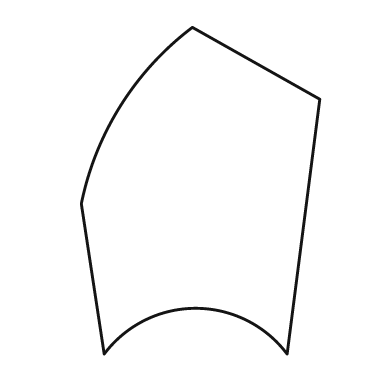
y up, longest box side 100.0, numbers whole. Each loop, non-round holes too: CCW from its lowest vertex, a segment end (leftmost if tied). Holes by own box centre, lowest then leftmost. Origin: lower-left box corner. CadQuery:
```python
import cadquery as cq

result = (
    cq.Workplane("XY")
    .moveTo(7.0, 0.0)
    .threePointArc((35.0, 14.0), (63.0, 0.0))
    .lineTo(73.0, 78.0)
    .lineTo(34.0, 100.0)
    .threePointArc((12.0, 76.0), (0.0, 46.0))
    .close()
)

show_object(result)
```